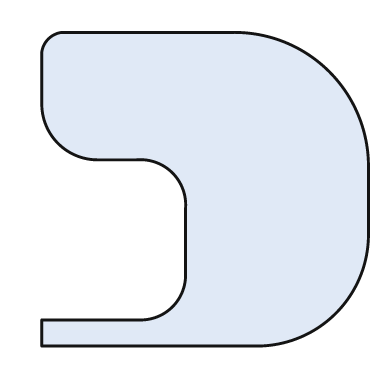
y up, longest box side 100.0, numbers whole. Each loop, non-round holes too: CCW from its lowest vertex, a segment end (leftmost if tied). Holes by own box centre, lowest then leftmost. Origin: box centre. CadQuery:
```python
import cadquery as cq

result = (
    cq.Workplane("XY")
    .moveTo(-50.0, -48.0)
    .lineTo(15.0, -48.0)
    .threePointArc((40.0, -38.0), (50.0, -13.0))
    .lineTo(50.0, 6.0)
    .threePointArc((38.0, 36.0), (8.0, 48.0))
    .lineTo(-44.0, 48.0)
    .threePointArc((-48.0, 46.0), (-50.0, 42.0))
    .lineTo(-50.0, 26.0)
    .threePointArc((-45.0, 14.0), (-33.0, 9.0))
    .lineTo(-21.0, 9.0)
    .threePointArc((-10.0, 5.0), (-6.0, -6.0))
    .lineTo(-6.0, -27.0)
    .threePointArc((-10.0, -36.0), (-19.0, -40.0))
    .lineTo(-50.0, -40.0)
    .close()
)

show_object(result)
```